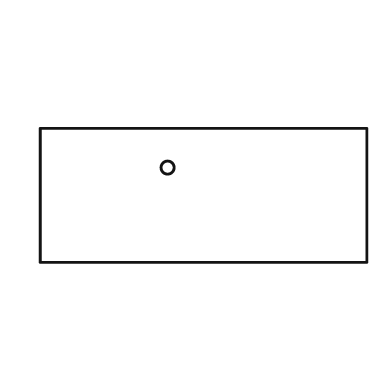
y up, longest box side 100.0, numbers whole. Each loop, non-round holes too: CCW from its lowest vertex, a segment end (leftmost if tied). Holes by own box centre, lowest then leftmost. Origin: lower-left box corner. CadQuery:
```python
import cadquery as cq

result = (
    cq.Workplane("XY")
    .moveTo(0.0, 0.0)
    .lineTo(100.0, 0.0)
    .lineTo(100.0, 41.0)
    .lineTo(0.0, 41.0)
    .close()
    .moveTo(39.0, 29.0)
    .circle(2.0)
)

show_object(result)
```